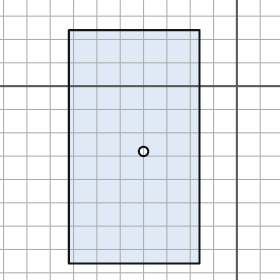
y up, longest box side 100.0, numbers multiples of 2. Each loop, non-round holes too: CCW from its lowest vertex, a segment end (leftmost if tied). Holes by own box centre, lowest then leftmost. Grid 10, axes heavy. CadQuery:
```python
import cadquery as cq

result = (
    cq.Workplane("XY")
    .moveTo(-72.0, -76.0)
    .lineTo(-16.0, -76.0)
    .lineTo(-16.0, 24.0)
    .lineTo(-72.0, 24.0)
    .close()
    .moveTo(-40.0, -28.0)
    .circle(2.0)
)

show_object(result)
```